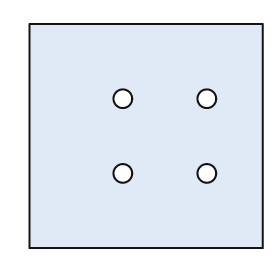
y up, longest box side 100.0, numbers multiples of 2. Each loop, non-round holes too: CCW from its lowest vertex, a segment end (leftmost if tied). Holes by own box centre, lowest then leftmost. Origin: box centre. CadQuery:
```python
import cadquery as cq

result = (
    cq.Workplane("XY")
    .moveTo(-50.0, -48.0)
    .lineTo(50.0, -48.0)
    .lineTo(50.0, 48.0)
    .lineTo(-50.0, 48.0)
    .close()
    .moveTo(-10.0, -16.0)
    .circle(4.0)
    .moveTo(26.0, -16.0)
    .circle(4.0)
    .moveTo(-10.0, 16.0)
    .circle(4.0)
    .moveTo(26.0, 16.0)
    .circle(4.0)
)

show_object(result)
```